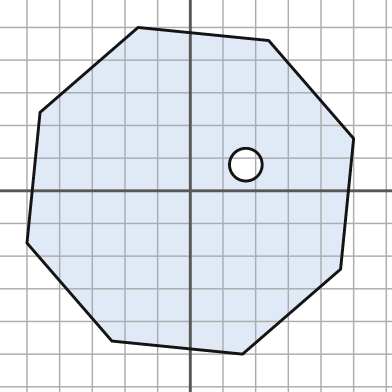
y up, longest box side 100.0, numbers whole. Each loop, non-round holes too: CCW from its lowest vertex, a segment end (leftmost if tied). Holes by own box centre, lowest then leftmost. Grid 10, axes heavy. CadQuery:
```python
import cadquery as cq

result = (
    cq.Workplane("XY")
    .moveTo(16.0, -50.0)
    .lineTo(46.0, -24.0)
    .lineTo(50.0, 16.0)
    .lineTo(24.0, 46.0)
    .lineTo(-16.0, 50.0)
    .lineTo(-46.0, 24.0)
    .lineTo(-50.0, -16.0)
    .lineTo(-24.0, -46.0)
    .close()
    .moveTo(17.0, 8.0)
    .circle(5.0)
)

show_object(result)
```